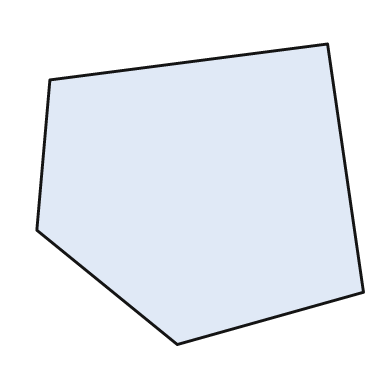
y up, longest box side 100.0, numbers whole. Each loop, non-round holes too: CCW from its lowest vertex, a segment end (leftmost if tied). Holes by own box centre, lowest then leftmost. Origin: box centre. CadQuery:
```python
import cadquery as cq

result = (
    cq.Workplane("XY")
    .moveTo(-7.0, -46.0)
    .lineTo(50.0, -30.0)
    .lineTo(39.0, 46.0)
    .lineTo(-46.0, 35.0)
    .lineTo(-50.0, -11.0)
    .close()
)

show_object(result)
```